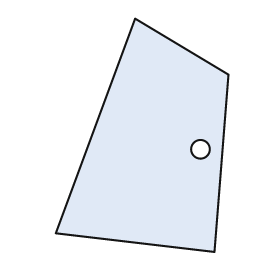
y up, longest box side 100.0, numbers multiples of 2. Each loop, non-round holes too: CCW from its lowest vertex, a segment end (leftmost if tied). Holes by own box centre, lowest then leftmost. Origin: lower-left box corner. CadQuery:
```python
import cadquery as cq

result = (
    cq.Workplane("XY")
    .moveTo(68.0, 0.0)
    .lineTo(74.0, 76.0)
    .lineTo(34.0, 100.0)
    .lineTo(0.0, 8.0)
    .close()
    .moveTo(62.0, 44.0)
    .circle(4.0)
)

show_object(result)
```